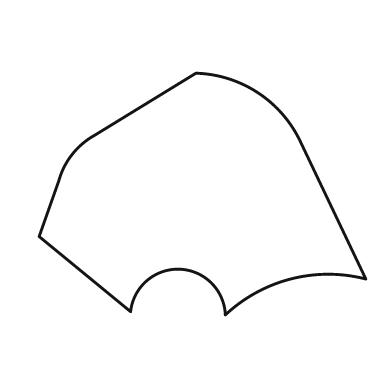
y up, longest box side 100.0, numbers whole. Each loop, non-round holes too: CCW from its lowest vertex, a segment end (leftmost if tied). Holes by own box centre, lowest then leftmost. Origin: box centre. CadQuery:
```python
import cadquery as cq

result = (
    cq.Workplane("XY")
    .moveTo(7.0, -37.0)
    .threePointArc((27.0, -26.0), (50.0, -26.0))
    .lineTo(30.0, 16.0)
    .threePointArc((17.0, 31.0), (-2.0, 37.0))
    .lineTo(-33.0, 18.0)
    .threePointArc((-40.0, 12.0), (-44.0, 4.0))
    .lineTo(-50.0, -13.0)
    .lineTo(-22.0, -36.0)
    .threePointArc((-7.0, -23.0), (7.0, -37.0))
    .close()
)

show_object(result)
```